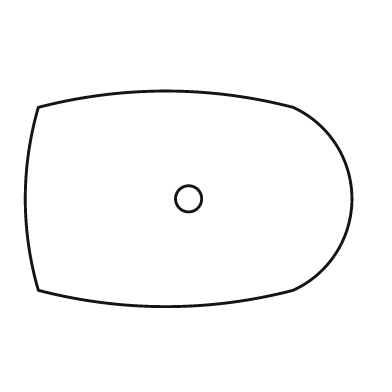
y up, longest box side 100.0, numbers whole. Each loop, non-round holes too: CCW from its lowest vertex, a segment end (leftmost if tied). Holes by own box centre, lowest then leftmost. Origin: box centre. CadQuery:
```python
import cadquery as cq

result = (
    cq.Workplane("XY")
    .moveTo(-46.0, -28.0)
    .threePointArc((-7.0, -33.0), (32.0, -28.0))
    .threePointArc((50.0, 0.0), (32.0, 28.0))
    .threePointArc((-7.0, 33.0), (-46.0, 28.0))
    .threePointArc((-50.0, 0.0), (-46.0, -28.0))
    .close()
    .moveTo(0.0, 0.0)
    .circle(4.0)
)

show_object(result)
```